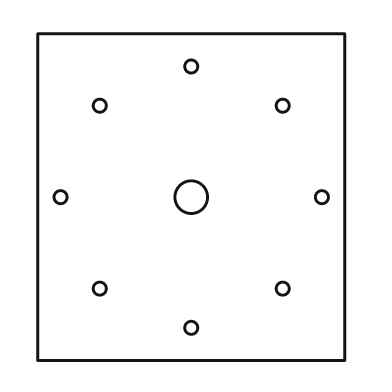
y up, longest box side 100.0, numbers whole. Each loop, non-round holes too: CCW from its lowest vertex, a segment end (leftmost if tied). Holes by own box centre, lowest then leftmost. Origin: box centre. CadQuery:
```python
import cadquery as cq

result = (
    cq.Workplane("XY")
    .moveTo(-47.0, -50.0)
    .lineTo(47.0, -50.0)
    .lineTo(47.0, 50.0)
    .lineTo(-47.0, 50.0)
    .close()
    .moveTo(0.0, -40.0)
    .circle(2.0)
    .moveTo(-28.0, -28.0)
    .circle(2.0)
    .moveTo(28.0, -28.0)
    .circle(2.0)
    .moveTo(-40.0, 0.0)
    .circle(2.0)
    .moveTo(0.0, 0.0)
    .circle(5.0)
    .moveTo(40.0, 0.0)
    .circle(2.0)
    .moveTo(-28.0, 28.0)
    .circle(2.0)
    .moveTo(28.0, 28.0)
    .circle(2.0)
    .moveTo(0.0, 40.0)
    .circle(2.0)
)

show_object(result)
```